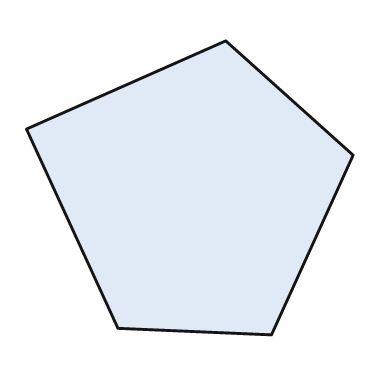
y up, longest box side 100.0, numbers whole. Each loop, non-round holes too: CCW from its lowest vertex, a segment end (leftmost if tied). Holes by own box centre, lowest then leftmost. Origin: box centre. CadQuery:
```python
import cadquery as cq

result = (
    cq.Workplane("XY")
    .moveTo(25.0, -45.0)
    .lineTo(50.0, 10.0)
    .lineTo(11.0, 45.0)
    .lineTo(-50.0, 18.0)
    .lineTo(-22.0, -43.0)
    .close()
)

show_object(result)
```